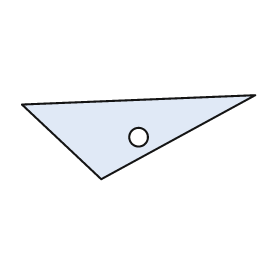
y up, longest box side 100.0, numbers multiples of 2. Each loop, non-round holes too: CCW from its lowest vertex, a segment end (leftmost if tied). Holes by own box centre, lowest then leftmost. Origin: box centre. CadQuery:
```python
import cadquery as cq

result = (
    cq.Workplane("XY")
    .moveTo(-16.0, -18.0)
    .lineTo(50.0, 18.0)
    .lineTo(-50.0, 14.0)
    .close()
    .moveTo(0.0, 0.0)
    .circle(4.0)
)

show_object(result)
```